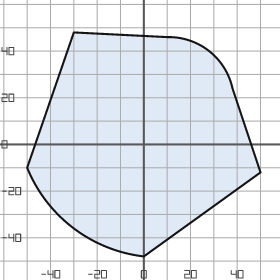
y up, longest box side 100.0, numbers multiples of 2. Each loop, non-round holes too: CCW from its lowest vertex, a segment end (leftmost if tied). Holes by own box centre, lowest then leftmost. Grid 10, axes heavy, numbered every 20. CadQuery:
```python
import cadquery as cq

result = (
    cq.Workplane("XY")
    .moveTo(0.0, -48.0)
    .lineTo(50.0, -12.0)
    .lineTo(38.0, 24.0)
    .threePointArc((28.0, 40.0), (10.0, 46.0))
    .lineTo(-30.0, 48.0)
    .lineTo(-50.0, -10.0)
    .threePointArc((-30.0, -36.0), (0.0, -48.0))
    .close()
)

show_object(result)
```